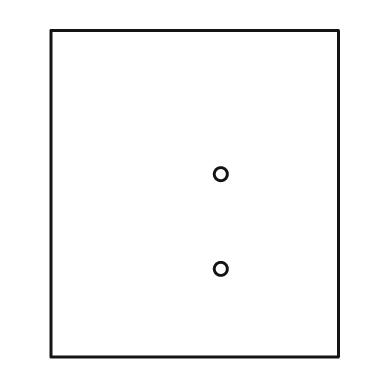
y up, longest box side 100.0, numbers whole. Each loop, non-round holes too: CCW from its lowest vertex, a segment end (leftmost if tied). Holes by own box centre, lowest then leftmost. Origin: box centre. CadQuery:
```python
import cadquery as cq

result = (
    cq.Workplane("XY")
    .moveTo(-44.0, -50.0)
    .lineTo(44.0, -50.0)
    .lineTo(44.0, 50.0)
    .lineTo(-44.0, 50.0)
    .close()
    .moveTo(8.0, -23.0)
    .circle(2.0)
    .moveTo(8.0, 6.0)
    .circle(2.0)
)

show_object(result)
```